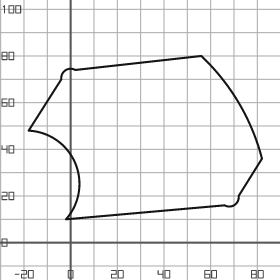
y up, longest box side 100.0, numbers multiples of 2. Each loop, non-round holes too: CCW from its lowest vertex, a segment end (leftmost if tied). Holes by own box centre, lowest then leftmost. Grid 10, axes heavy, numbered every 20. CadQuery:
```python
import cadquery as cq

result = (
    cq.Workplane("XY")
    .moveTo(-2.0, 10.0)
    .lineTo(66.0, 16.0)
    .threePointArc((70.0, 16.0), (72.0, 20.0))
    .lineTo(82.0, 36.0)
    .threePointArc((72.0, 60.0), (56.0, 80.0))
    .lineTo(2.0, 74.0)
    .threePointArc((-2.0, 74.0), (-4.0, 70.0))
    .lineTo(-18.0, 48.0)
    .threePointArc((2.0, 34.0), (-2.0, 10.0))
    .close()
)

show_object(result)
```